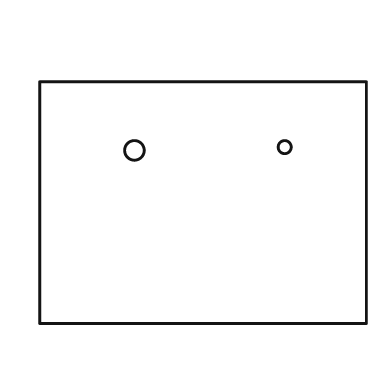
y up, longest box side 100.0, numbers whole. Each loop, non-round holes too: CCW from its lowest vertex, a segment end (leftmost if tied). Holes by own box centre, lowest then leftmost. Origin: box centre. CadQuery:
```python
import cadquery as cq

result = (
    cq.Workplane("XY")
    .moveTo(-50.0, -37.0)
    .lineTo(50.0, -37.0)
    .lineTo(50.0, 37.0)
    .lineTo(-50.0, 37.0)
    .close()
    .moveTo(-21.0, 16.0)
    .circle(3.0)
    .moveTo(25.0, 17.0)
    .circle(2.0)
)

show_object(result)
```